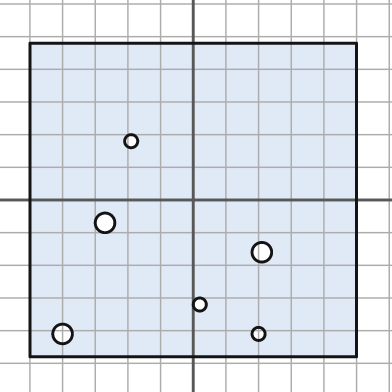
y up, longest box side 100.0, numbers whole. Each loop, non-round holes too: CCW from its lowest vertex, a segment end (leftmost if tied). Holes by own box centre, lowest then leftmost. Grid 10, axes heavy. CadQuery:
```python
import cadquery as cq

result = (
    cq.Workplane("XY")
    .moveTo(-50.0, -48.0)
    .lineTo(50.0, -48.0)
    .lineTo(50.0, 48.0)
    .lineTo(-50.0, 48.0)
    .close()
    .moveTo(-40.0, -41.0)
    .circle(3.0)
    .moveTo(20.0, -41.0)
    .circle(2.0)
    .moveTo(2.0, -32.0)
    .circle(2.0)
    .moveTo(21.0, -16.0)
    .circle(3.0)
    .moveTo(-27.0, -7.0)
    .circle(3.0)
    .moveTo(-19.0, 18.0)
    .circle(2.0)
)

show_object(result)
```